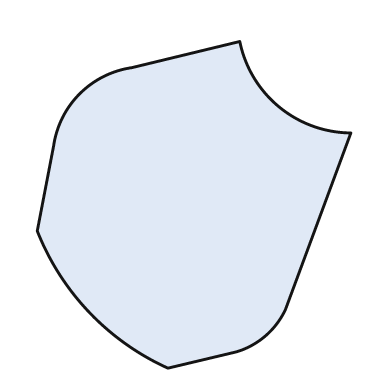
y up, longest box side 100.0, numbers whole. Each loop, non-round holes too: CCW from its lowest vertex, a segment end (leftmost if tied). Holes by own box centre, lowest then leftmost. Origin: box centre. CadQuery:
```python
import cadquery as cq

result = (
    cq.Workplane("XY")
    .moveTo(-8.0, -50.0)
    .lineTo(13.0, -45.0)
    .threePointArc((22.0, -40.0), (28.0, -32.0))
    .lineTo(48.0, 22.0)
    .threePointArc((26.0, 30.0), (14.0, 50.0))
    .lineTo(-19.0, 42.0)
    .threePointArc((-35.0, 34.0), (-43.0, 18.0))
    .lineTo(-48.0, -8.0)
    .threePointArc((-32.0, -33.0), (-8.0, -50.0))
    .close()
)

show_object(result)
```